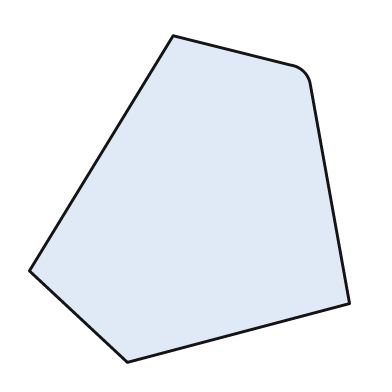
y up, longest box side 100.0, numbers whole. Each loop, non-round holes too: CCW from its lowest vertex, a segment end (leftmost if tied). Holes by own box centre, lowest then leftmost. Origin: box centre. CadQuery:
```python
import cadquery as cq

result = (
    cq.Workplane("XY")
    .moveTo(-19.0, -50.0)
    .lineTo(49.0, -32.0)
    .lineTo(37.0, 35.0)
    .threePointArc((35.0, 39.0), (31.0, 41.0))
    .lineTo(-5.0, 50.0)
    .lineTo(-49.0, -22.0)
    .close()
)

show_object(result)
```